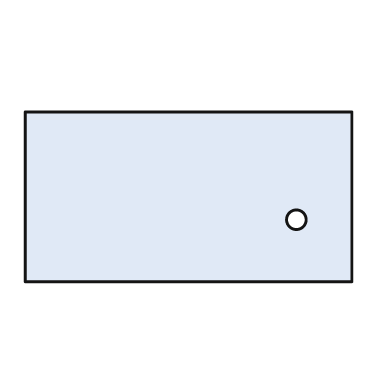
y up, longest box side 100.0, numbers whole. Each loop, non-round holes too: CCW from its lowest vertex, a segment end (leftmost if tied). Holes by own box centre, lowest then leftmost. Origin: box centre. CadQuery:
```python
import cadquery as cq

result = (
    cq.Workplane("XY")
    .moveTo(-50.0, -26.0)
    .lineTo(50.0, -26.0)
    .lineTo(50.0, 26.0)
    .lineTo(-50.0, 26.0)
    .close()
    .moveTo(33.0, -7.0)
    .circle(3.0)
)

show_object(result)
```